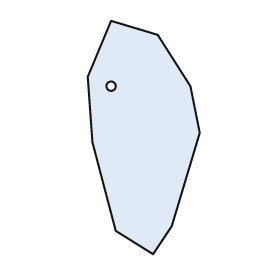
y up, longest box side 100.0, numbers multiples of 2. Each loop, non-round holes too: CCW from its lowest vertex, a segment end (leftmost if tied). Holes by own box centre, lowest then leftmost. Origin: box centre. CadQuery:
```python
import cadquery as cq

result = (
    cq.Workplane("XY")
    .moveTo(4.0, -50.0)
    .lineTo(12.0, -38.0)
    .lineTo(24.0, 2.0)
    .lineTo(20.0, 22.0)
    .lineTo(6.0, 44.0)
    .lineTo(-14.0, 50.0)
    .lineTo(-24.0, 26.0)
    .lineTo(-22.0, -2.0)
    .lineTo(-12.0, -40.0)
    .close()
    .moveTo(-14.0, 22.0)
    .circle(2.0)
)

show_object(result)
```